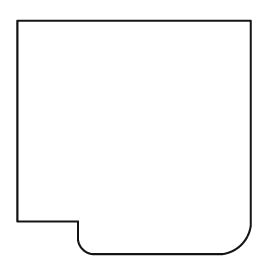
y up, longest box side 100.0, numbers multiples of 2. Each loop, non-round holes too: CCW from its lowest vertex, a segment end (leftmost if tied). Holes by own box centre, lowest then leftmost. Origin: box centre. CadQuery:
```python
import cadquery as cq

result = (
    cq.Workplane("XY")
    .moveTo(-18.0, -50.0)
    .lineTo(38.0, -50.0)
    .threePointArc((46.0, -46.0), (50.0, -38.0))
    .lineTo(50.0, 50.0)
    .lineTo(-50.0, 50.0)
    .lineTo(-50.0, -36.0)
    .lineTo(-24.0, -36.0)
    .lineTo(-24.0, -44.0)
    .threePointArc((-22.0, -48.0), (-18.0, -50.0))
    .close()
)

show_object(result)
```